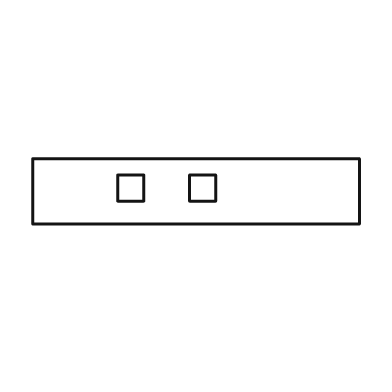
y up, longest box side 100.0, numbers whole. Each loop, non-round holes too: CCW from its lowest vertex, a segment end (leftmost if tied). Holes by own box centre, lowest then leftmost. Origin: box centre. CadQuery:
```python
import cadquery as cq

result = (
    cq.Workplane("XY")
    .moveTo(-50.0, -10.0)
    .lineTo(50.0, -10.0)
    .lineTo(50.0, 10.0)
    .lineTo(-50.0, 10.0)
    .close()
    .moveTo(-24.0, -3.0)
    .lineTo(-16.0, -3.0)
    .lineTo(-16.0, 5.0)
    .lineTo(-24.0, 5.0)
    .close()
    .moveTo(-2.0, -3.0)
    .lineTo(6.0, -3.0)
    .lineTo(6.0, 5.0)
    .lineTo(-2.0, 5.0)
    .close()
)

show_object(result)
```